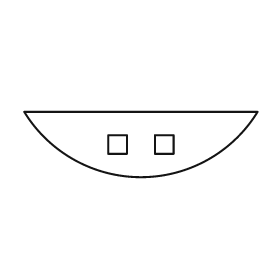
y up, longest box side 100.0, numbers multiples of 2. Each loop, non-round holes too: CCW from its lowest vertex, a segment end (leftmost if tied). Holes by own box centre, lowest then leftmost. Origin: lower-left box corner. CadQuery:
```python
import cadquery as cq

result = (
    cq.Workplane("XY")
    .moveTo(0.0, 28.0)
    .threePointArc((50.0, 0.0), (100.0, 28.0))
    .close()
    .moveTo(36.0, 10.0)
    .lineTo(44.0, 10.0)
    .lineTo(44.0, 18.0)
    .lineTo(36.0, 18.0)
    .close()
    .moveTo(56.0, 10.0)
    .lineTo(64.0, 10.0)
    .lineTo(64.0, 18.0)
    .lineTo(56.0, 18.0)
    .close()
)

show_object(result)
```